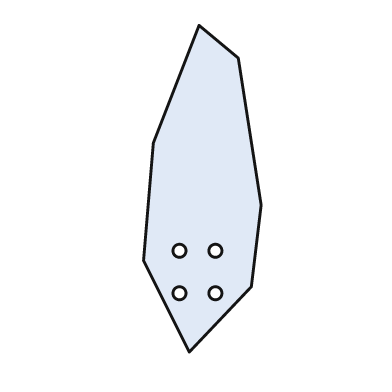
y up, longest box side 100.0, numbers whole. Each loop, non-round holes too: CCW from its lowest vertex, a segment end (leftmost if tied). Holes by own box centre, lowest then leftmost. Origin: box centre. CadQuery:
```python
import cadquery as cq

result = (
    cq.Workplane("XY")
    .moveTo(-4.0, -50.0)
    .lineTo(15.0, -30.0)
    .lineTo(18.0, -5.0)
    .lineTo(11.0, 40.0)
    .lineTo(-1.0, 50.0)
    .lineTo(-15.0, 14.0)
    .lineTo(-18.0, -22.0)
    .close()
    .moveTo(-7.0, -32.0)
    .circle(2.0)
    .moveTo(4.0, -32.0)
    .circle(2.0)
    .moveTo(-7.0, -19.0)
    .circle(2.0)
    .moveTo(4.0, -19.0)
    .circle(2.0)
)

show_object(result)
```